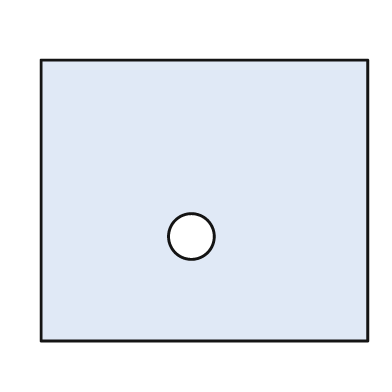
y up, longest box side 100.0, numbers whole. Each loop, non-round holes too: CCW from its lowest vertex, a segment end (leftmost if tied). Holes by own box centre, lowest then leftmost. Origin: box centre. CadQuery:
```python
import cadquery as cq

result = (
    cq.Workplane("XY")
    .moveTo(-50.0, -43.0)
    .lineTo(50.0, -43.0)
    .lineTo(50.0, 43.0)
    .lineTo(-50.0, 43.0)
    .close()
    .moveTo(-4.0, -11.0)
    .circle(7.0)
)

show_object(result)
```